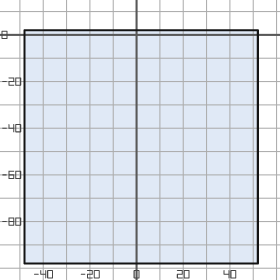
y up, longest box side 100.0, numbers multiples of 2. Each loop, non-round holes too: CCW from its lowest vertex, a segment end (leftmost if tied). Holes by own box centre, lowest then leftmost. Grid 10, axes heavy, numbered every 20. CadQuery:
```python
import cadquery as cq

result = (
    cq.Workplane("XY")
    .moveTo(-48.0, -98.0)
    .lineTo(52.0, -98.0)
    .lineTo(52.0, 2.0)
    .lineTo(-48.0, 2.0)
    .close()
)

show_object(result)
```